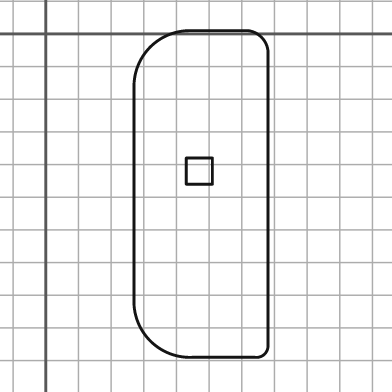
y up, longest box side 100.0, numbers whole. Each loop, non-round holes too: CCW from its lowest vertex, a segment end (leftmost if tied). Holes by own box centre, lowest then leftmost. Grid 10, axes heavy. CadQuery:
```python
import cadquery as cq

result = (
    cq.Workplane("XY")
    .moveTo(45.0, -99.0)
    .lineTo(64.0, -99.0)
    .threePointArc((67.0, -98.0), (68.0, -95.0))
    .lineTo(68.0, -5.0)
    .threePointArc((66.0, -1.0), (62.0, 1.0))
    .lineTo(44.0, 1.0)
    .threePointArc((32.0, -4.0), (27.0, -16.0))
    .lineTo(27.0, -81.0)
    .threePointArc((32.0, -94.0), (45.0, -99.0))
    .close()
    .moveTo(43.0, -46.0)
    .lineTo(51.0, -46.0)
    .lineTo(51.0, -38.0)
    .lineTo(43.0, -38.0)
    .close()
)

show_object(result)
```